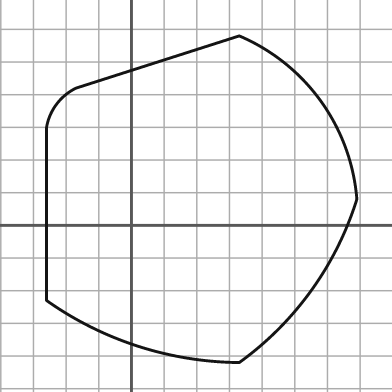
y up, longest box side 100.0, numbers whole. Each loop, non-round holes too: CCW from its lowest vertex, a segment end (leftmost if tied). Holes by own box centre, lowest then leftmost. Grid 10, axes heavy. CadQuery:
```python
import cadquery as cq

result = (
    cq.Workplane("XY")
    .moveTo(33.0, -42.0)
    .threePointArc((55.0, -20.0), (69.0, 8.0))
    .threePointArc((58.0, 38.0), (33.0, 58.0))
    .lineTo(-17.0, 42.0)
    .threePointArc((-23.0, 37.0), (-26.0, 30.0))
    .lineTo(-26.0, -23.0)
    .threePointArc((2.0, -37.0), (33.0, -42.0))
    .close()
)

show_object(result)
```